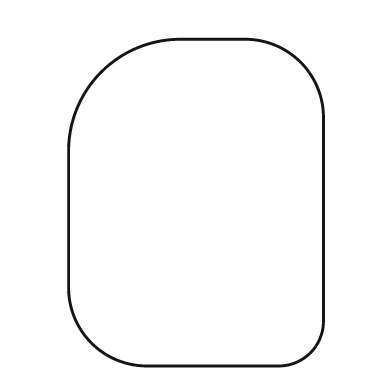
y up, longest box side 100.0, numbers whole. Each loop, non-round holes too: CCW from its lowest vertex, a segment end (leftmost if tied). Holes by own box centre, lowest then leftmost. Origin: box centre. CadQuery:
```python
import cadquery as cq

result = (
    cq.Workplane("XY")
    .moveTo(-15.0, -50.0)
    .lineTo(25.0, -50.0)
    .threePointArc((35.0, -46.0), (39.0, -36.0))
    .lineTo(39.0, 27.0)
    .threePointArc((32.0, 43.0), (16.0, 50.0))
    .lineTo(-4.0, 50.0)
    .threePointArc((-29.0, 40.0), (-39.0, 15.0))
    .lineTo(-39.0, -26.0)
    .threePointArc((-32.0, -43.0), (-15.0, -50.0))
    .close()
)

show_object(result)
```